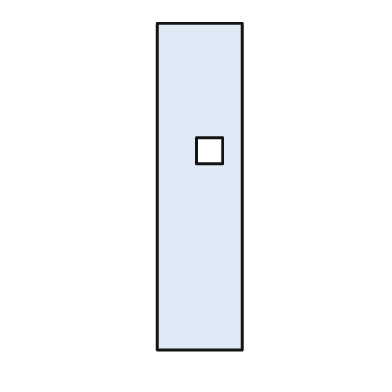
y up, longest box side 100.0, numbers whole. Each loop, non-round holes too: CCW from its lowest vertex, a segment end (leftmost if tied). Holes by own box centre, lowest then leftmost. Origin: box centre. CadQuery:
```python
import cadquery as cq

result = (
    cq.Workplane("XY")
    .moveTo(-13.0, -50.0)
    .lineTo(13.0, -50.0)
    .lineTo(13.0, 50.0)
    .lineTo(-13.0, 50.0)
    .close()
    .moveTo(-1.0, 7.0)
    .lineTo(7.0, 7.0)
    .lineTo(7.0, 15.0)
    .lineTo(-1.0, 15.0)
    .close()
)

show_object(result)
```